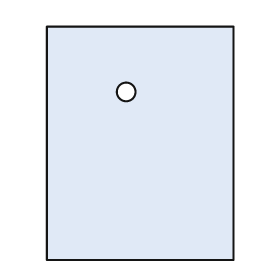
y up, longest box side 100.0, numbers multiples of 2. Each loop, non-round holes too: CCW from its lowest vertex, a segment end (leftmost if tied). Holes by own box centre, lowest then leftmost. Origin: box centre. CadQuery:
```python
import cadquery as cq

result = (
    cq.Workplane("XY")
    .moveTo(-40.0, -50.0)
    .lineTo(40.0, -50.0)
    .lineTo(40.0, 50.0)
    .lineTo(-40.0, 50.0)
    .close()
    .moveTo(-6.0, 22.0)
    .circle(4.0)
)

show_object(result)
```